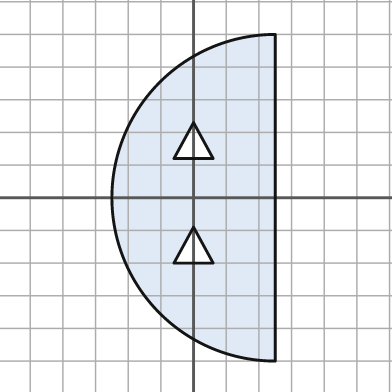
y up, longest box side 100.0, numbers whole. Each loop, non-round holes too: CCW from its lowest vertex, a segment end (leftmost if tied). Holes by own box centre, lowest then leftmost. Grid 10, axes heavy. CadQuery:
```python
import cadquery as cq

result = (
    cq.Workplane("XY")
    .moveTo(25.0, -50.0)
    .lineTo(25.0, 50.0)
    .threePointArc((-25.0, 0.0), (25.0, -50.0))
    .close()
    .moveTo(-6.0, -20.0)
    .lineTo(6.0, -20.0)
    .lineTo(0.0, -9.0)
    .close()
    .moveTo(-6.0, 12.0)
    .lineTo(6.0, 12.0)
    .lineTo(0.0, 23.0)
    .close()
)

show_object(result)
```